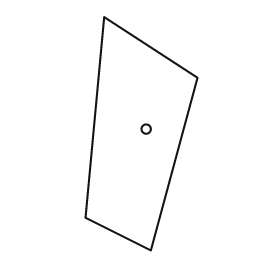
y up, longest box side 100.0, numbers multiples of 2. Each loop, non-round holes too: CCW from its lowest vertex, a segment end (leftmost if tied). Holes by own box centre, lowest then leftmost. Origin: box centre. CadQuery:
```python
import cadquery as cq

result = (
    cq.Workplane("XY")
    .moveTo(4.0, -50.0)
    .lineTo(24.0, 24.0)
    .lineTo(-16.0, 50.0)
    .lineTo(-24.0, -36.0)
    .close()
    .moveTo(2.0, 2.0)
    .circle(2.0)
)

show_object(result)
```